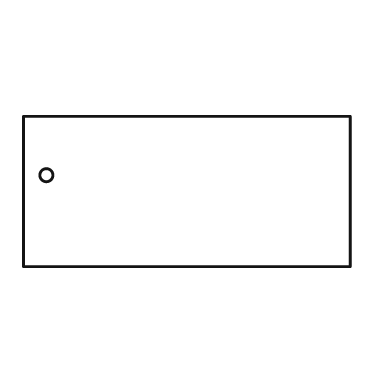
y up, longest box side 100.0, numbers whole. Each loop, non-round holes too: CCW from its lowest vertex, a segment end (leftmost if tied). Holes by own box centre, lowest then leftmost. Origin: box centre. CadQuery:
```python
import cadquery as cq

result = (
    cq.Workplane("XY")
    .moveTo(-50.0, -23.0)
    .lineTo(50.0, -23.0)
    .lineTo(50.0, 23.0)
    .lineTo(-50.0, 23.0)
    .close()
    .moveTo(-43.0, 5.0)
    .circle(2.0)
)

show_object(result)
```